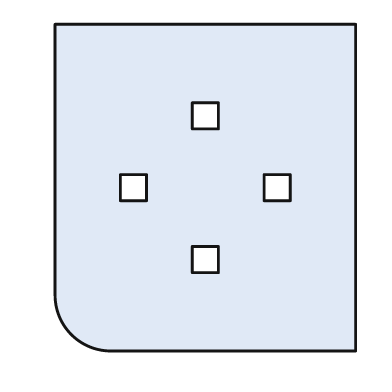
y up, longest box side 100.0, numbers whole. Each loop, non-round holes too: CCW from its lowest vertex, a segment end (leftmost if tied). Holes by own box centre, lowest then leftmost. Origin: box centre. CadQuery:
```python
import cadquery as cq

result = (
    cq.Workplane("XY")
    .moveTo(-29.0, -50.0)
    .lineTo(46.0, -50.0)
    .lineTo(46.0, 50.0)
    .lineTo(-46.0, 50.0)
    .lineTo(-46.0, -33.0)
    .threePointArc((-41.0, -45.0), (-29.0, -50.0))
    .close()
    .moveTo(-4.0, -26.0)
    .lineTo(4.0, -26.0)
    .lineTo(4.0, -18.0)
    .lineTo(-4.0, -18.0)
    .close()
    .moveTo(-26.0, -4.0)
    .lineTo(-18.0, -4.0)
    .lineTo(-18.0, 4.0)
    .lineTo(-26.0, 4.0)
    .close()
    .moveTo(18.0, -4.0)
    .lineTo(26.0, -4.0)
    .lineTo(26.0, 4.0)
    .lineTo(18.0, 4.0)
    .close()
    .moveTo(-4.0, 18.0)
    .lineTo(4.0, 18.0)
    .lineTo(4.0, 26.0)
    .lineTo(-4.0, 26.0)
    .close()
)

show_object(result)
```